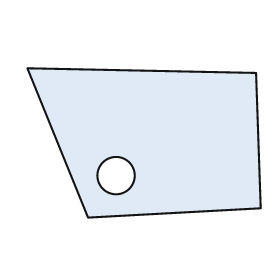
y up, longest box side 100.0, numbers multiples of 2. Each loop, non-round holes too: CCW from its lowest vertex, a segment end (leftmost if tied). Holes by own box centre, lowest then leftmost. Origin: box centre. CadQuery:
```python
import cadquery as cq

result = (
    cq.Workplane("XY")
    .moveTo(-24.0, -32.0)
    .lineTo(50.0, -28.0)
    .lineTo(48.0, 30.0)
    .lineTo(-50.0, 32.0)
    .close()
    .moveTo(-12.0, -14.0)
    .circle(8.0)
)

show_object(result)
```